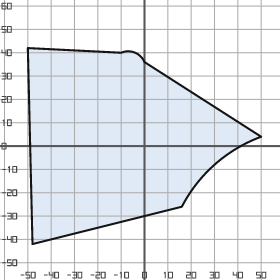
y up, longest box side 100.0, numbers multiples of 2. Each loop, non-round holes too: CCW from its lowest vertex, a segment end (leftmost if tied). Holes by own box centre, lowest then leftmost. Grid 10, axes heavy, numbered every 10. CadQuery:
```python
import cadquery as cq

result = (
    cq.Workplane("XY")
    .moveTo(-48.0, -42.0)
    .lineTo(16.0, -26.0)
    .threePointArc((30.0, -8.0), (50.0, 4.0))
    .lineTo(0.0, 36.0)
    .threePointArc((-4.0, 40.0), (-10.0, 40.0))
    .lineTo(-50.0, 42.0)
    .close()
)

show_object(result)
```